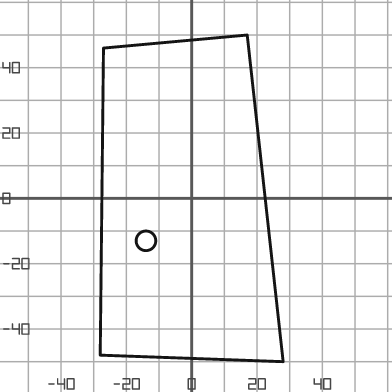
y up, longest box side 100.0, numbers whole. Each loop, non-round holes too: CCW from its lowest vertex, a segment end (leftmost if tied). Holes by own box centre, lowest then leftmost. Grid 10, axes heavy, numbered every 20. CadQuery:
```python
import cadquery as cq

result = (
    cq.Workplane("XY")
    .moveTo(28.0, -50.0)
    .lineTo(17.0, 50.0)
    .lineTo(-27.0, 46.0)
    .lineTo(-28.0, -48.0)
    .close()
    .moveTo(-14.0, -13.0)
    .circle(3.0)
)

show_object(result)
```